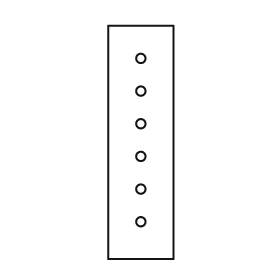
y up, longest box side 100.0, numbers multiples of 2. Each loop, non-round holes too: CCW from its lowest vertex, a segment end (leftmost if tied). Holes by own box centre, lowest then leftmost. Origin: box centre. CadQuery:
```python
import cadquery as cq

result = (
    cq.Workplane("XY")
    .moveTo(-14.0, -50.0)
    .lineTo(14.0, -50.0)
    .lineTo(14.0, 50.0)
    .lineTo(-14.0, 50.0)
    .close()
    .moveTo(0.0, -34.0)
    .circle(2.0)
    .moveTo(0.0, -20.0)
    .circle(2.0)
    .moveTo(0.0, -6.0)
    .circle(2.0)
    .moveTo(0.0, 8.0)
    .circle(2.0)
    .moveTo(0.0, 22.0)
    .circle(2.0)
    .moveTo(0.0, 36.0)
    .circle(2.0)
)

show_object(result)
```